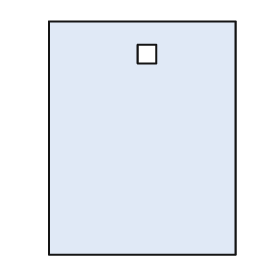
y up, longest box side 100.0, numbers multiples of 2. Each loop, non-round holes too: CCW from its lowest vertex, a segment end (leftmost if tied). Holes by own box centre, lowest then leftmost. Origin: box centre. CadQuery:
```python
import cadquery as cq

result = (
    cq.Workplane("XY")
    .moveTo(-40.0, -50.0)
    .lineTo(40.0, -50.0)
    .lineTo(40.0, 50.0)
    .lineTo(-40.0, 50.0)
    .close()
    .moveTo(-2.0, 32.0)
    .lineTo(6.0, 32.0)
    .lineTo(6.0, 40.0)
    .lineTo(-2.0, 40.0)
    .close()
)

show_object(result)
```